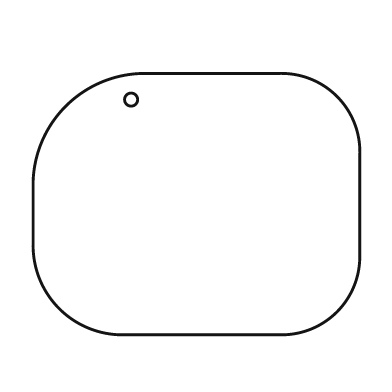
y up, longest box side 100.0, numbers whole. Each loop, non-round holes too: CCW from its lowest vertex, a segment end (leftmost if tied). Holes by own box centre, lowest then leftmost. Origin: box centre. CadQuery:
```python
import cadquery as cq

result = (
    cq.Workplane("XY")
    .moveTo(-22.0, -40.0)
    .lineTo(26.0, -40.0)
    .threePointArc((43.0, -33.0), (50.0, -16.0))
    .lineTo(50.0, 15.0)
    .threePointArc((43.0, 33.0), (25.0, 40.0))
    .lineTo(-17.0, 40.0)
    .threePointArc((-40.0, 30.0), (-50.0, 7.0))
    .lineTo(-50.0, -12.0)
    .threePointArc((-42.0, -32.0), (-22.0, -40.0))
    .close()
    .moveTo(-20.0, 32.0)
    .circle(2.0)
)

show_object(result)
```